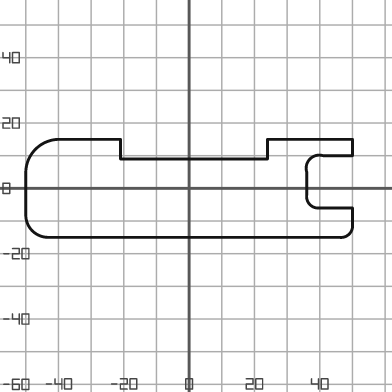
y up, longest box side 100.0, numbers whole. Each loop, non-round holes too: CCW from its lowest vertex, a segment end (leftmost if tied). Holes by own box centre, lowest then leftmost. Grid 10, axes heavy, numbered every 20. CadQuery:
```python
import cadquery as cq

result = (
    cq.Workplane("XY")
    .moveTo(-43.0, -15.0)
    .lineTo(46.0, -15.0)
    .threePointArc((49.0, -14.0), (50.0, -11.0))
    .lineTo(50.0, -6.0)
    .lineTo(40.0, -6.0)
    .threePointArc((37.0, -5.0), (36.0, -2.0))
    .lineTo(36.0, 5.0)
    .threePointArc((37.0, 9.0), (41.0, 10.0))
    .lineTo(50.0, 10.0)
    .lineTo(50.0, 15.0)
    .lineTo(24.0, 15.0)
    .lineTo(24.0, 9.0)
    .lineTo(-21.0, 9.0)
    .lineTo(-21.0, 15.0)
    .lineTo(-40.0, 15.0)
    .threePointArc((-47.0, 12.0), (-50.0, 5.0))
    .lineTo(-50.0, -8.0)
    .threePointArc((-48.0, -13.0), (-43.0, -15.0))
    .close()
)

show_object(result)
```